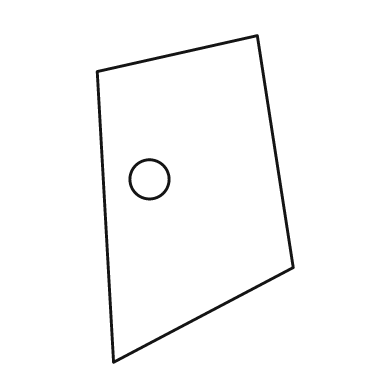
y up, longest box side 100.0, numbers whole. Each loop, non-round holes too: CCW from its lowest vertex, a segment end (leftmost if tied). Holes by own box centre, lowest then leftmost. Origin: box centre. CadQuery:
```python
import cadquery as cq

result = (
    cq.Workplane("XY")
    .moveTo(-25.0, -50.0)
    .lineTo(30.0, -21.0)
    .lineTo(19.0, 50.0)
    .lineTo(-30.0, 39.0)
    .close()
    .moveTo(-14.0, 6.0)
    .circle(6.0)
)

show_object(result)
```